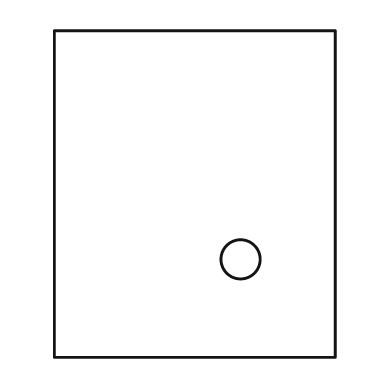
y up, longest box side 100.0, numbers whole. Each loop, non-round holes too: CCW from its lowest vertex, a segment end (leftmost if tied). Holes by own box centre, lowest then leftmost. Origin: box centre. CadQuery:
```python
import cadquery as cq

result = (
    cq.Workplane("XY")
    .moveTo(-43.0, -50.0)
    .lineTo(43.0, -50.0)
    .lineTo(43.0, 50.0)
    .lineTo(-43.0, 50.0)
    .close()
    .moveTo(14.0, -20.0)
    .circle(6.0)
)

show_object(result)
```